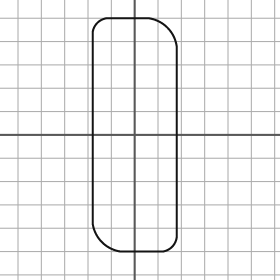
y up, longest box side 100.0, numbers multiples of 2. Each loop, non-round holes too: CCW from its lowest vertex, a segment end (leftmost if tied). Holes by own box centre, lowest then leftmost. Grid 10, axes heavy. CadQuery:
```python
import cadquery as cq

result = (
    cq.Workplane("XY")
    .moveTo(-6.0, -50.0)
    .lineTo(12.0, -50.0)
    .threePointArc((16.0, -48.0), (18.0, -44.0))
    .lineTo(18.0, 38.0)
    .threePointArc((14.0, 46.0), (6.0, 50.0))
    .lineTo(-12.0, 50.0)
    .threePointArc((-16.0, 48.0), (-18.0, 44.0))
    .lineTo(-18.0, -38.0)
    .threePointArc((-14.0, -46.0), (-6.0, -50.0))
    .close()
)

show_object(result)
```